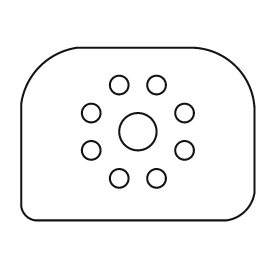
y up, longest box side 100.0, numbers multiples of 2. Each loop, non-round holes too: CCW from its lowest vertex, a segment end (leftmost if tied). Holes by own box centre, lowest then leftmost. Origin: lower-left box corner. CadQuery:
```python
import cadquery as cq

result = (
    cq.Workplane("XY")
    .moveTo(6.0, 0.0)
    .lineTo(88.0, 0.0)
    .threePointArc((96.0, 4.0), (100.0, 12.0))
    .lineTo(100.0, 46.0)
    .threePointArc((92.0, 66.0), (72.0, 74.0))
    .lineTo(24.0, 74.0)
    .threePointArc((8.0, 66.0), (0.0, 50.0))
    .lineTo(0.0, 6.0)
    .threePointArc((2.0, 2.0), (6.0, 0.0))
    .close()
    .moveTo(42.0, 18.0)
    .circle(4.0)
    .moveTo(58.0, 18.0)
    .circle(4.0)
    .moveTo(30.0, 30.0)
    .circle(4.0)
    .moveTo(70.0, 30.0)
    .circle(4.0)
    .moveTo(50.0, 38.0)
    .circle(8.0)
    .moveTo(30.0, 46.0)
    .circle(4.0)
    .moveTo(70.0, 46.0)
    .circle(4.0)
    .moveTo(42.0, 58.0)
    .circle(4.0)
    .moveTo(58.0, 58.0)
    .circle(4.0)
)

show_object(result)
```